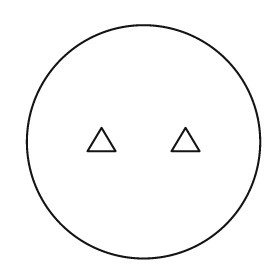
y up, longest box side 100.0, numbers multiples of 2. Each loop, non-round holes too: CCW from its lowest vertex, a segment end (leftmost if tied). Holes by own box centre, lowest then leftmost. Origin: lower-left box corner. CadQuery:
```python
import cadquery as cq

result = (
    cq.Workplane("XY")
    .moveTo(50.0, 50.0)
    .circle(50.0)
    .moveTo(26.0, 46.0)
    .lineTo(38.0, 46.0)
    .lineTo(32.0, 56.0)
    .close()
    .moveTo(62.0, 46.0)
    .lineTo(74.0, 46.0)
    .lineTo(68.0, 56.0)
    .close()
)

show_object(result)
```